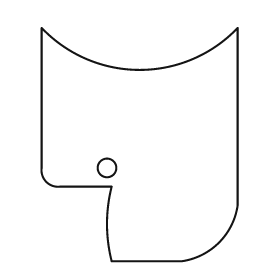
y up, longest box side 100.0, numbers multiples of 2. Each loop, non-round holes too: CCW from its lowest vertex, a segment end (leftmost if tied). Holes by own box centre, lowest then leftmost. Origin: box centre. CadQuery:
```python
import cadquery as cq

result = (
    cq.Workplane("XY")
    .moveTo(-12.0, -50.0)
    .lineTo(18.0, -50.0)
    .threePointArc((34.0, -42.0), (42.0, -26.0))
    .lineTo(42.0, 50.0)
    .threePointArc((0.0, 32.0), (-42.0, 50.0))
    .lineTo(-42.0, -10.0)
    .threePointArc((-40.0, -16.0), (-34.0, -18.0))
    .lineTo(-12.0, -18.0)
    .threePointArc((-14.0, -34.0), (-12.0, -50.0))
    .close()
    .moveTo(-14.0, -10.0)
    .circle(4.0)
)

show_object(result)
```